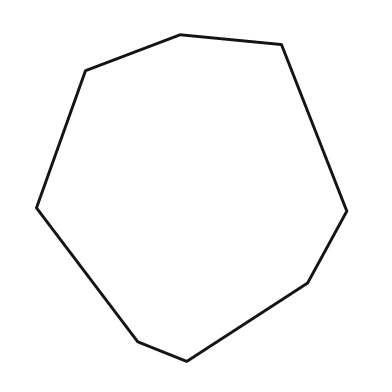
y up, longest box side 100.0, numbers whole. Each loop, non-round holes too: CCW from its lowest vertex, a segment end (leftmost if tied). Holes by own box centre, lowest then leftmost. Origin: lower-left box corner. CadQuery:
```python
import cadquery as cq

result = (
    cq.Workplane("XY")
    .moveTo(46.0, 0.0)
    .lineTo(83.0, 24.0)
    .lineTo(95.0, 46.0)
    .lineTo(75.0, 97.0)
    .lineTo(44.0, 100.0)
    .lineTo(15.0, 89.0)
    .lineTo(0.0, 47.0)
    .lineTo(31.0, 6.0)
    .close()
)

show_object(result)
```